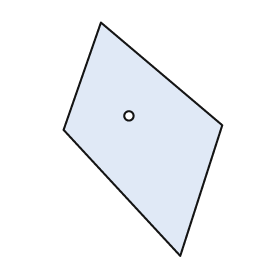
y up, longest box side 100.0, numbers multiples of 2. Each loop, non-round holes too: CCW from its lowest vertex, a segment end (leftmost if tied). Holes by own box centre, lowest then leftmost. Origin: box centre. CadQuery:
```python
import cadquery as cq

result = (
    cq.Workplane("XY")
    .moveTo(16.0, -50.0)
    .lineTo(34.0, 6.0)
    .lineTo(-18.0, 50.0)
    .lineTo(-34.0, 4.0)
    .close()
    .moveTo(-6.0, 10.0)
    .circle(2.0)
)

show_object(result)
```